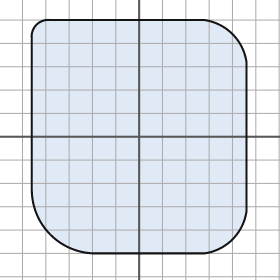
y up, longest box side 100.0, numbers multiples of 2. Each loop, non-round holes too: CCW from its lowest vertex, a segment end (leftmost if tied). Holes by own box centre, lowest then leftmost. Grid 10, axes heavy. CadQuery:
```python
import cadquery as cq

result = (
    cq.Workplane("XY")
    .moveTo(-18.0, -50.0)
    .lineTo(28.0, -50.0)
    .threePointArc((40.0, -44.0), (46.0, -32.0))
    .lineTo(46.0, 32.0)
    .threePointArc((40.0, 44.0), (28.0, 50.0))
    .lineTo(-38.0, 50.0)
    .threePointArc((-44.0, 48.0), (-46.0, 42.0))
    .lineTo(-46.0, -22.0)
    .threePointArc((-38.0, -42.0), (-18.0, -50.0))
    .close()
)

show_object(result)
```